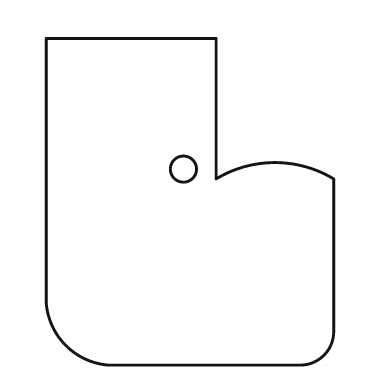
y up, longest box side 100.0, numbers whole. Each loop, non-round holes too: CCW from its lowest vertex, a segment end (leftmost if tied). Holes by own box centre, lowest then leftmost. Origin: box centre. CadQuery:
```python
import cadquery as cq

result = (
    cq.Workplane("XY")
    .moveTo(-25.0, -50.0)
    .lineTo(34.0, -50.0)
    .threePointArc((41.0, -47.0), (44.0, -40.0))
    .lineTo(44.0, 7.0)
    .threePointArc((26.0, 12.0), (8.0, 7.0))
    .lineTo(8.0, 50.0)
    .lineTo(-44.0, 50.0)
    .lineTo(-44.0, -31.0)
    .threePointArc((-38.0, -44.0), (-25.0, -50.0))
    .close()
    .moveTo(-2.0, 10.0)
    .circle(4.0)
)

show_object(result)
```